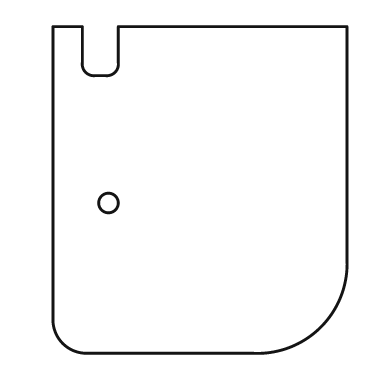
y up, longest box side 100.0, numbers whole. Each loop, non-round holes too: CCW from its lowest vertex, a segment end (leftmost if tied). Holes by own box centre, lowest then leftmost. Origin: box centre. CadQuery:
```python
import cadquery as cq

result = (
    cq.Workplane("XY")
    .moveTo(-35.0, -50.0)
    .lineTo(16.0, -50.0)
    .threePointArc((37.0, -42.0), (45.0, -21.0))
    .lineTo(45.0, 50.0)
    .lineTo(-25.0, 50.0)
    .lineTo(-25.0, 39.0)
    .threePointArc((-26.0, 36.0), (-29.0, 35.0))
    .lineTo(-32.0, 35.0)
    .threePointArc((-35.0, 36.0), (-36.0, 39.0))
    .lineTo(-36.0, 50.0)
    .lineTo(-45.0, 50.0)
    .lineTo(-45.0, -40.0)
    .threePointArc((-42.0, -47.0), (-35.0, -50.0))
    .close()
    .moveTo(-28.0, -4.0)
    .circle(3.0)
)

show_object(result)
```